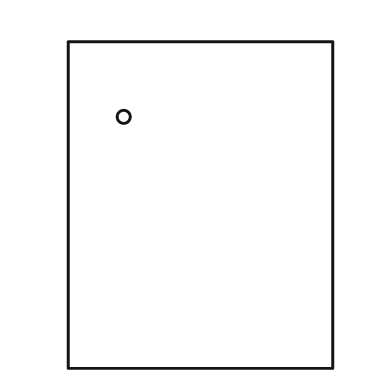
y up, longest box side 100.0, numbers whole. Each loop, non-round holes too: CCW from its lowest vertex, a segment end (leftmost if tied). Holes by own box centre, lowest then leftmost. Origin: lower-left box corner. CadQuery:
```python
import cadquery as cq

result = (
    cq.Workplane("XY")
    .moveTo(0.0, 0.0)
    .lineTo(81.0, 0.0)
    .lineTo(81.0, 100.0)
    .lineTo(0.0, 100.0)
    .close()
    .moveTo(17.0, 77.0)
    .circle(2.0)
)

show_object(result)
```